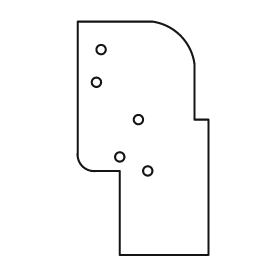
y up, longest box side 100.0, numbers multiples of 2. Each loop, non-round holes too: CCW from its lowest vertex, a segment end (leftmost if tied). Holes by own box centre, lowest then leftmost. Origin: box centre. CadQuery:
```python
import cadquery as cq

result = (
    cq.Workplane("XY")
    .moveTo(-10.0, -50.0)
    .lineTo(28.0, -50.0)
    .lineTo(28.0, 8.0)
    .lineTo(22.0, 8.0)
    .lineTo(22.0, 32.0)
    .threePointArc((16.0, 44.0), (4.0, 50.0))
    .lineTo(-28.0, 50.0)
    .lineTo(-28.0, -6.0)
    .threePointArc((-26.0, -12.0), (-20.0, -14.0))
    .lineTo(-10.0, -14.0)
    .close()
    .moveTo(2.0, -14.0)
    .circle(2.0)
    .moveTo(-10.0, -8.0)
    .circle(2.0)
    .moveTo(-2.0, 8.0)
    .circle(2.0)
    .moveTo(-20.0, 24.0)
    .circle(2.0)
    .moveTo(-18.0, 38.0)
    .circle(2.0)
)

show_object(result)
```